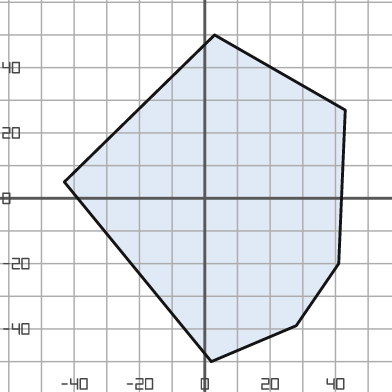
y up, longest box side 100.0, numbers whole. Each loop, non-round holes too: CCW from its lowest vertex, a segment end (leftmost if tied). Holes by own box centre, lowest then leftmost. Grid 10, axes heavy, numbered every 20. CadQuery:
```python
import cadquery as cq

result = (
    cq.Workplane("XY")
    .moveTo(2.0, -50.0)
    .lineTo(28.0, -39.0)
    .lineTo(41.0, -20.0)
    .lineTo(43.0, 27.0)
    .lineTo(3.0, 50.0)
    .lineTo(-43.0, 5.0)
    .close()
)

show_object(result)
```